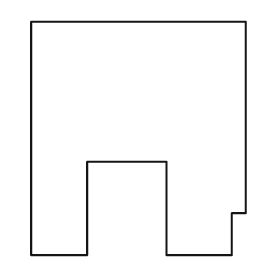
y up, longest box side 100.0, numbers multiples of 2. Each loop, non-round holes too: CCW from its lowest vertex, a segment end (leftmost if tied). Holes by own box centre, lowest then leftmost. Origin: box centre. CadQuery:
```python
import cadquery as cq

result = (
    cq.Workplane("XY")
    .moveTo(-46.0, -50.0)
    .lineTo(-22.0, -50.0)
    .lineTo(-22.0, -10.0)
    .lineTo(12.0, -10.0)
    .lineTo(12.0, -50.0)
    .lineTo(40.0, -50.0)
    .lineTo(40.0, -32.0)
    .lineTo(46.0, -32.0)
    .lineTo(46.0, 50.0)
    .lineTo(-46.0, 50.0)
    .close()
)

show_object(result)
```